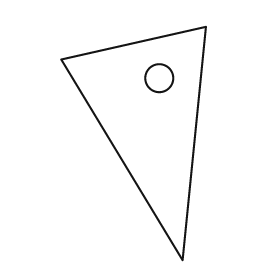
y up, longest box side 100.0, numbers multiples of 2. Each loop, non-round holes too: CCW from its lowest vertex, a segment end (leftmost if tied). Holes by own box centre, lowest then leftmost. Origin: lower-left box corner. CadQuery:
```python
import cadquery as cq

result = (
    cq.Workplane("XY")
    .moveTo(52.0, 0.0)
    .lineTo(62.0, 100.0)
    .lineTo(0.0, 86.0)
    .close()
    .moveTo(42.0, 78.0)
    .circle(6.0)
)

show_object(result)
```